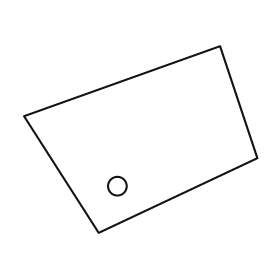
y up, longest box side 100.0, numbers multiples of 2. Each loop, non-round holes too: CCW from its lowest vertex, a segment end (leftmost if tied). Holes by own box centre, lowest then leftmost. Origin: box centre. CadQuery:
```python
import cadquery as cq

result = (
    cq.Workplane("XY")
    .moveTo(-18.0, -40.0)
    .lineTo(50.0, -8.0)
    .lineTo(34.0, 40.0)
    .lineTo(-50.0, 10.0)
    .close()
    .moveTo(-10.0, -20.0)
    .circle(4.0)
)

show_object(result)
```